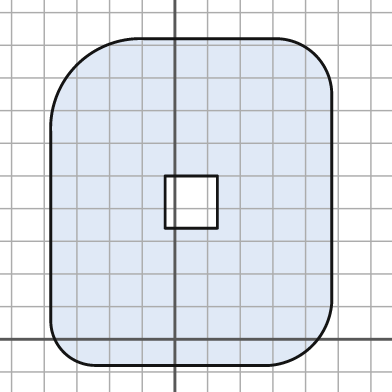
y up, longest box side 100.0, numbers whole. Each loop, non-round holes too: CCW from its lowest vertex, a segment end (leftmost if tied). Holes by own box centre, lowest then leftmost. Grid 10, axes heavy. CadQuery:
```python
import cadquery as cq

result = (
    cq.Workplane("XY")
    .moveTo(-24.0, -8.0)
    .lineTo(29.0, -8.0)
    .threePointArc((42.0, -2.0), (48.0, 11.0))
    .lineTo(48.0, 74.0)
    .threePointArc((43.0, 87.0), (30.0, 92.0))
    .lineTo(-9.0, 92.0)
    .threePointArc((-30.0, 84.0), (-38.0, 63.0))
    .lineTo(-38.0, 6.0)
    .threePointArc((-34.0, -4.0), (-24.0, -8.0))
    .close()
    .moveTo(-3.0, 34.0)
    .lineTo(13.0, 34.0)
    .lineTo(13.0, 50.0)
    .lineTo(-3.0, 50.0)
    .close()
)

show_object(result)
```